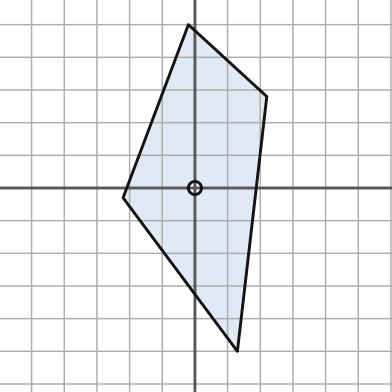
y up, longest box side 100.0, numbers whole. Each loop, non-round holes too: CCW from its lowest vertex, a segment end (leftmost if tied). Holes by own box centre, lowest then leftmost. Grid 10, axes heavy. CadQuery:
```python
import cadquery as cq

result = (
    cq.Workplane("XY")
    .moveTo(13.0, -50.0)
    .lineTo(22.0, 28.0)
    .lineTo(-2.0, 50.0)
    .lineTo(-22.0, -3.0)
    .close()
    .moveTo(0.0, 0.0)
    .circle(2.0)
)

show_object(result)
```